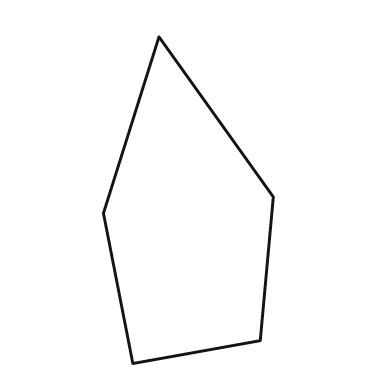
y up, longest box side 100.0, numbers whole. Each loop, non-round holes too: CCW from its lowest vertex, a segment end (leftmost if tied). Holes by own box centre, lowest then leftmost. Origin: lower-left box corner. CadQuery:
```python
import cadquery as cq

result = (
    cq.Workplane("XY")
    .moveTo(9.0, 0.0)
    .lineTo(48.0, 7.0)
    .lineTo(52.0, 51.0)
    .lineTo(17.0, 100.0)
    .lineTo(0.0, 46.0)
    .close()
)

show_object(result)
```